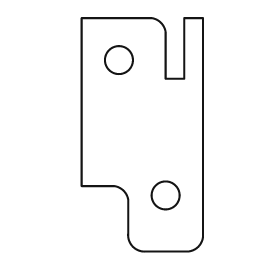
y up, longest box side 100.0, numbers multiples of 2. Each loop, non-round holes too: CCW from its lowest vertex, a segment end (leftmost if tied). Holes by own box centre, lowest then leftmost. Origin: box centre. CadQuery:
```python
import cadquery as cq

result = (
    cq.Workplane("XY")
    .moveTo(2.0, -50.0)
    .lineTo(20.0, -50.0)
    .threePointArc((24.0, -48.0), (26.0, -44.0))
    .lineTo(26.0, 50.0)
    .lineTo(18.0, 50.0)
    .lineTo(18.0, 24.0)
    .lineTo(10.0, 24.0)
    .lineTo(10.0, 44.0)
    .threePointArc((8.0, 48.0), (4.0, 50.0))
    .lineTo(-26.0, 50.0)
    .lineTo(-26.0, -22.0)
    .lineTo(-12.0, -22.0)
    .threePointArc((-8.0, -24.0), (-6.0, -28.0))
    .lineTo(-6.0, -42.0)
    .threePointArc((-4.0, -48.0), (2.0, -50.0))
    .close()
    .moveTo(10.0, -26.0)
    .circle(6.0)
    .moveTo(-10.0, 32.0)
    .circle(6.0)
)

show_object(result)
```